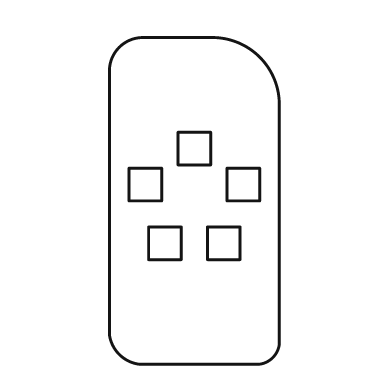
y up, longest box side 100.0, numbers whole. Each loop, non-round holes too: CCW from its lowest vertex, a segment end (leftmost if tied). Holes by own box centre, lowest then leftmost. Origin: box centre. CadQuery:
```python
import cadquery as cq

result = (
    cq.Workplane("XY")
    .moveTo(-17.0, -50.0)
    .lineTo(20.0, -50.0)
    .threePointArc((24.0, -48.0), (26.0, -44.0))
    .lineTo(26.0, 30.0)
    .threePointArc((20.0, 44.0), (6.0, 50.0))
    .lineTo(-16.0, 50.0)
    .threePointArc((-23.0, 47.0), (-26.0, 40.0))
    .lineTo(-26.0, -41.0)
    .threePointArc((-23.0, -47.0), (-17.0, -50.0))
    .close()
    .moveTo(-14.0, -18.0)
    .lineTo(-4.0, -18.0)
    .lineTo(-4.0, -8.0)
    .lineTo(-14.0, -8.0)
    .close()
    .moveTo(4.0, -18.0)
    .lineTo(14.0, -18.0)
    .lineTo(14.0, -8.0)
    .lineTo(4.0, -8.0)
    .close()
    .moveTo(-20.0, 0.0)
    .lineTo(-10.0, 0.0)
    .lineTo(-10.0, 10.0)
    .lineTo(-20.0, 10.0)
    .close()
    .moveTo(10.0, 0.0)
    .lineTo(20.0, 0.0)
    .lineTo(20.0, 10.0)
    .lineTo(10.0, 10.0)
    .close()
    .moveTo(-5.0, 11.0)
    .lineTo(5.0, 11.0)
    .lineTo(5.0, 21.0)
    .lineTo(-5.0, 21.0)
    .close()
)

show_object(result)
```